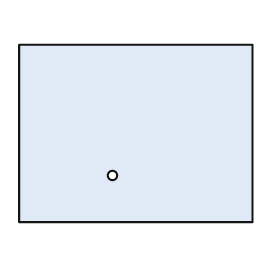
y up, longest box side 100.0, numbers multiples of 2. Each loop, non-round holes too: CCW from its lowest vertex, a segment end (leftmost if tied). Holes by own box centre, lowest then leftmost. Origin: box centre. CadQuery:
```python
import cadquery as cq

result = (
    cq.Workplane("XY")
    .moveTo(-50.0, -38.0)
    .lineTo(50.0, -38.0)
    .lineTo(50.0, 38.0)
    .lineTo(-50.0, 38.0)
    .close()
    .moveTo(-10.0, -18.0)
    .circle(2.0)
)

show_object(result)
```